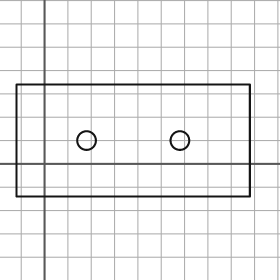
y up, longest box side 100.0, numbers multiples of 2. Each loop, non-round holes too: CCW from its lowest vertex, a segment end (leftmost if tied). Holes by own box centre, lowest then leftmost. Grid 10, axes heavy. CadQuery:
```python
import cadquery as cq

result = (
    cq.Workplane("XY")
    .moveTo(-12.0, -14.0)
    .lineTo(88.0, -14.0)
    .lineTo(88.0, 34.0)
    .lineTo(-12.0, 34.0)
    .close()
    .moveTo(18.0, 10.0)
    .circle(4.0)
    .moveTo(58.0, 10.0)
    .circle(4.0)
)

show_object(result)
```